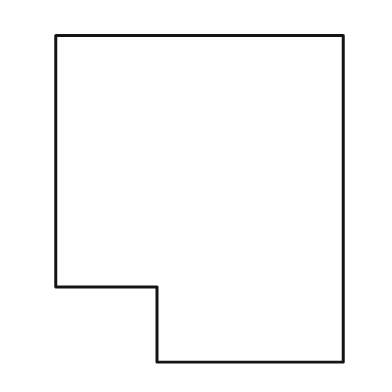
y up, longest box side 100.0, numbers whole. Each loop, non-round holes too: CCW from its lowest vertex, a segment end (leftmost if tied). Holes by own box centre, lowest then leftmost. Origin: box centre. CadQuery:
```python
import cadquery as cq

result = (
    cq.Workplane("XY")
    .moveTo(-13.0, -50.0)
    .lineTo(44.0, -50.0)
    .lineTo(44.0, 50.0)
    .lineTo(-44.0, 50.0)
    .lineTo(-44.0, -27.0)
    .lineTo(-13.0, -27.0)
    .close()
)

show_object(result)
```